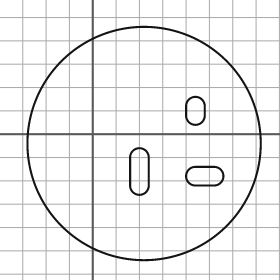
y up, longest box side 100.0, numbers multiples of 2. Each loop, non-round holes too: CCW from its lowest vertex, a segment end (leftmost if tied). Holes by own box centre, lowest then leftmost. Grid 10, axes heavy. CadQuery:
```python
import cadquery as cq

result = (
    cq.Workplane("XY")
    .moveTo(22.0, -4.0)
    .circle(50.0)
    .moveTo(44.0, -22.0)
    .lineTo(52.0, -22.0)
    .threePointArc((56.0, -18.0), (52.0, -14.0))
    .lineTo(44.0, -14.0)
    .threePointArc((40.0, -18.0), (44.0, -22.0))
    .close()
    .moveTo(16.0, -22.0)
    .threePointArc((20.0, -26.0), (24.0, -22.0))
    .lineTo(24.0, -10.0)
    .threePointArc((20.0, -6.0), (16.0, -10.0))
    .close()
    .moveTo(40.0, 8.0)
    .threePointArc((44.0, 4.0), (48.0, 8.0))
    .lineTo(48.0, 12.0)
    .threePointArc((44.0, 16.0), (40.0, 12.0))
    .close()
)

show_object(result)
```